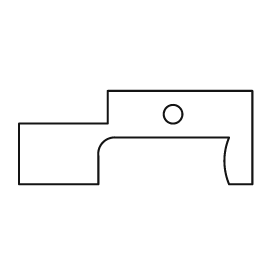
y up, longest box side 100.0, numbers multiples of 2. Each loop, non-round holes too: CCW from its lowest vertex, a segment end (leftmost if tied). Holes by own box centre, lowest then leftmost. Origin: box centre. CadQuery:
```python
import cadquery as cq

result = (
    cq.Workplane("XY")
    .moveTo(-50.0, -20.0)
    .lineTo(-16.0, -20.0)
    .lineTo(-16.0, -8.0)
    .threePointArc((-14.0, -2.0), (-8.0, 0.0))
    .lineTo(40.0, 0.0)
    .threePointArc((38.0, -10.0), (40.0, -20.0))
    .lineTo(50.0, -20.0)
    .lineTo(50.0, 20.0)
    .lineTo(-12.0, 20.0)
    .lineTo(-12.0, 6.0)
    .lineTo(-50.0, 6.0)
    .close()
    .moveTo(16.0, 10.0)
    .circle(4.0)
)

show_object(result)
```